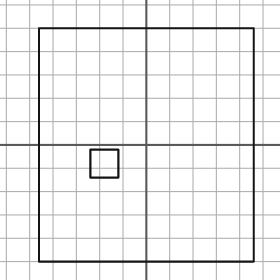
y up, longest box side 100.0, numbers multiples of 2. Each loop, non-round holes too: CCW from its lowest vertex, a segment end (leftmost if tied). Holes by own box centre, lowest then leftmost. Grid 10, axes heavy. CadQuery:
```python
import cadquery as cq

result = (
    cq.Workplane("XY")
    .moveTo(-46.0, -50.0)
    .lineTo(46.0, -50.0)
    .lineTo(46.0, 50.0)
    .lineTo(-46.0, 50.0)
    .close()
    .moveTo(-24.0, -14.0)
    .lineTo(-12.0, -14.0)
    .lineTo(-12.0, -2.0)
    .lineTo(-24.0, -2.0)
    .close()
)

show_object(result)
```